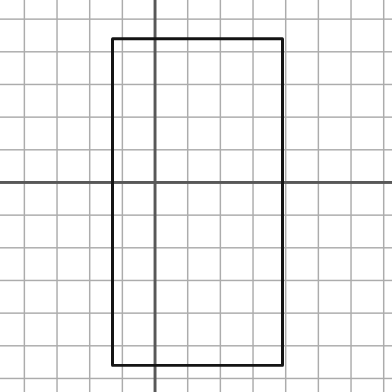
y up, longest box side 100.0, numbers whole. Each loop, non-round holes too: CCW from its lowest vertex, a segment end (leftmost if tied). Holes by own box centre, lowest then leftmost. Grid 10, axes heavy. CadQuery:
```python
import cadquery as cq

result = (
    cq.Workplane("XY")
    .moveTo(-13.0, -56.0)
    .lineTo(39.0, -56.0)
    .lineTo(39.0, 44.0)
    .lineTo(-13.0, 44.0)
    .close()
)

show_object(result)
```